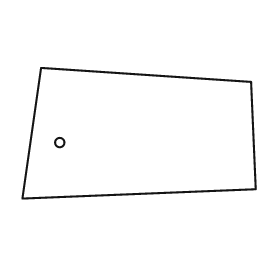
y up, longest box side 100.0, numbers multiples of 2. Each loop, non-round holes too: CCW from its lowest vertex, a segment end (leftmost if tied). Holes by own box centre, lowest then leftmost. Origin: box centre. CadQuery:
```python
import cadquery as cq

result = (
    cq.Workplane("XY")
    .moveTo(-50.0, -28.0)
    .lineTo(50.0, -24.0)
    .lineTo(48.0, 22.0)
    .lineTo(-42.0, 28.0)
    .close()
    .moveTo(-34.0, -4.0)
    .circle(2.0)
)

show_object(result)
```